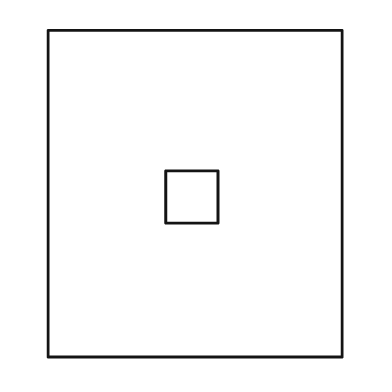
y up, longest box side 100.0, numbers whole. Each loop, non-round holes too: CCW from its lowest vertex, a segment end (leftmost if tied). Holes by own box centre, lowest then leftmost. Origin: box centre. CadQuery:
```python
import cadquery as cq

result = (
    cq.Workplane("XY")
    .moveTo(-45.0, -50.0)
    .lineTo(45.0, -50.0)
    .lineTo(45.0, 50.0)
    .lineTo(-45.0, 50.0)
    .close()
    .moveTo(-9.0, -9.0)
    .lineTo(7.0, -9.0)
    .lineTo(7.0, 7.0)
    .lineTo(-9.0, 7.0)
    .close()
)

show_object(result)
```